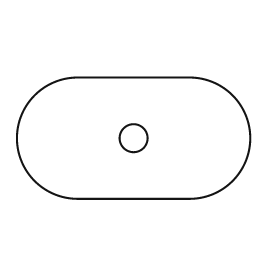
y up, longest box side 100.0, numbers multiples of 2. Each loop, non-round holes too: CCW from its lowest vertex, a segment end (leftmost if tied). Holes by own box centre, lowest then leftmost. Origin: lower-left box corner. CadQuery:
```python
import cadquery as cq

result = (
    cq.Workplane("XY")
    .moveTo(26.0, 0.0)
    .lineTo(74.0, 0.0)
    .threePointArc((100.0, 26.0), (74.0, 52.0))
    .lineTo(26.0, 52.0)
    .threePointArc((0.0, 26.0), (26.0, 0.0))
    .close()
    .moveTo(50.0, 26.0)
    .circle(6.0)
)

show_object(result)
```